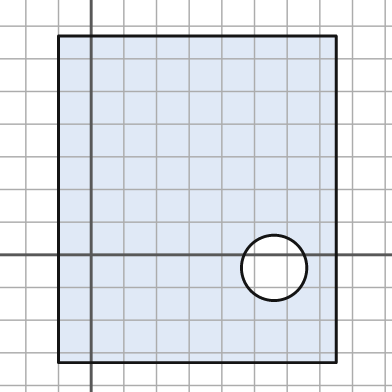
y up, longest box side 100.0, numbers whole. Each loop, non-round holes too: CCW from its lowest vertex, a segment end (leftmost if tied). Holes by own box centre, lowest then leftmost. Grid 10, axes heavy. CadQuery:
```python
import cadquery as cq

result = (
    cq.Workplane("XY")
    .moveTo(-10.0, -33.0)
    .lineTo(75.0, -33.0)
    .lineTo(75.0, 67.0)
    .lineTo(-10.0, 67.0)
    .close()
    .moveTo(56.0, -4.0)
    .circle(10.0)
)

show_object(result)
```